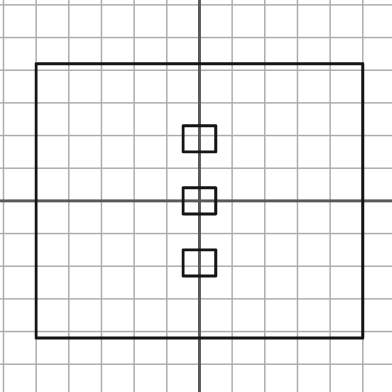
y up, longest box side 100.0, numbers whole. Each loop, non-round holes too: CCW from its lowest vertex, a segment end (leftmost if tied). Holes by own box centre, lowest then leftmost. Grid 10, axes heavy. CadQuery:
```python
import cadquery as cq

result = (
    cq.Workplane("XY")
    .moveTo(-50.0, -42.0)
    .lineTo(50.0, -42.0)
    .lineTo(50.0, 42.0)
    .lineTo(-50.0, 42.0)
    .close()
    .moveTo(-5.0, -23.0)
    .lineTo(5.0, -23.0)
    .lineTo(5.0, -15.0)
    .lineTo(-5.0, -15.0)
    .close()
    .moveTo(-5.0, -4.0)
    .lineTo(5.0, -4.0)
    .lineTo(5.0, 4.0)
    .lineTo(-5.0, 4.0)
    .close()
    .moveTo(-5.0, 15.0)
    .lineTo(5.0, 15.0)
    .lineTo(5.0, 23.0)
    .lineTo(-5.0, 23.0)
    .close()
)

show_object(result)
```